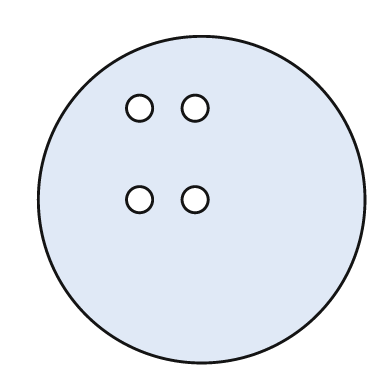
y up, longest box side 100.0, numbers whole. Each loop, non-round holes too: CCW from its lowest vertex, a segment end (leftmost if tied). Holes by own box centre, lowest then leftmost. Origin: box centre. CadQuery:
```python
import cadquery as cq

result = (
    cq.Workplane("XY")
    .moveTo(0.0, 0.0)
    .circle(50.0)
    .moveTo(-19.0, 0.0)
    .circle(4.0)
    .moveTo(-2.0, 0.0)
    .circle(4.0)
    .moveTo(-19.0, 28.0)
    .circle(4.0)
    .moveTo(-2.0, 28.0)
    .circle(4.0)
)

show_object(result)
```